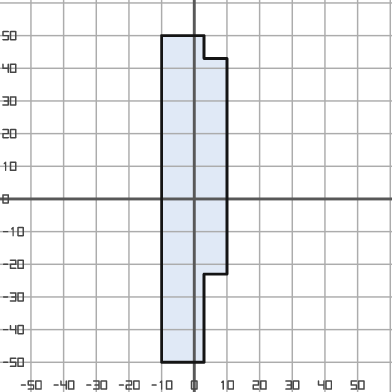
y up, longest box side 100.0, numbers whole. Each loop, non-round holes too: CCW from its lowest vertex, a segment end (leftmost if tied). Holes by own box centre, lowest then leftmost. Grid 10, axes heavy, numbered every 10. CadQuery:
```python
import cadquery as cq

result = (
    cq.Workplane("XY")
    .moveTo(-10.0, -50.0)
    .lineTo(3.0, -50.0)
    .lineTo(3.0, -23.0)
    .lineTo(10.0, -23.0)
    .lineTo(10.0, 43.0)
    .lineTo(3.0, 43.0)
    .lineTo(3.0, 50.0)
    .lineTo(-10.0, 50.0)
    .close()
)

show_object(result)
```